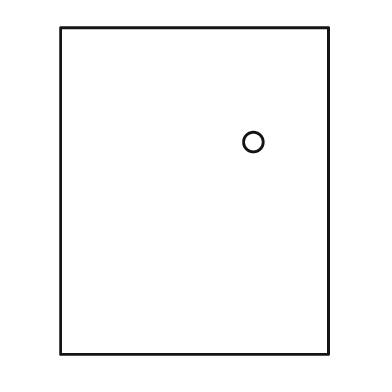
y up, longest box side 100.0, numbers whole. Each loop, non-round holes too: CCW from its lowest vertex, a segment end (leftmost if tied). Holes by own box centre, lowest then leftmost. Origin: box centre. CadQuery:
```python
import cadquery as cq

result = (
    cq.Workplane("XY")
    .moveTo(-41.0, -50.0)
    .lineTo(41.0, -50.0)
    .lineTo(41.0, 50.0)
    .lineTo(-41.0, 50.0)
    .close()
    .moveTo(18.0, 15.0)
    .circle(3.0)
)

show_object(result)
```